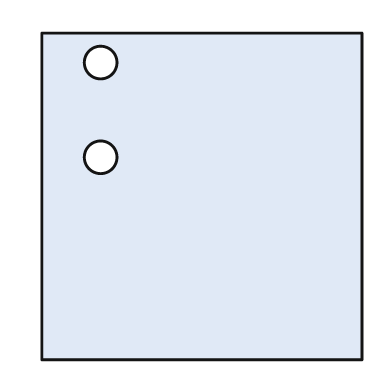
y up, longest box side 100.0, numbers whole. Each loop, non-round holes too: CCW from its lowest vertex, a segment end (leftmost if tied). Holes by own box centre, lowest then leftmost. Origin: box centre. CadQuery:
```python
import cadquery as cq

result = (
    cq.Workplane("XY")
    .moveTo(-49.0, -50.0)
    .lineTo(49.0, -50.0)
    .lineTo(49.0, 50.0)
    .lineTo(-49.0, 50.0)
    .close()
    .moveTo(-31.0, 12.0)
    .circle(5.0)
    .moveTo(-31.0, 41.0)
    .circle(5.0)
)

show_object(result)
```